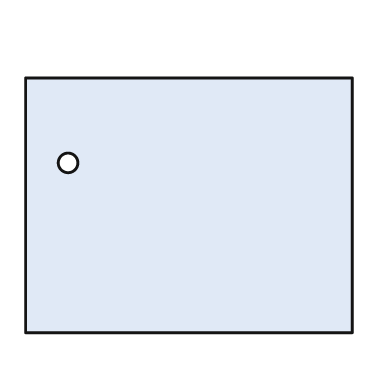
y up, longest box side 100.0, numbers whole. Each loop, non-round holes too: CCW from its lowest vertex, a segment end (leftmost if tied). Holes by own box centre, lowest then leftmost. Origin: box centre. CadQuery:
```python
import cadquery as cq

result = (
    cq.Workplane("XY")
    .moveTo(-50.0, -39.0)
    .lineTo(50.0, -39.0)
    .lineTo(50.0, 39.0)
    .lineTo(-50.0, 39.0)
    .close()
    .moveTo(-37.0, 13.0)
    .circle(3.0)
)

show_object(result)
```